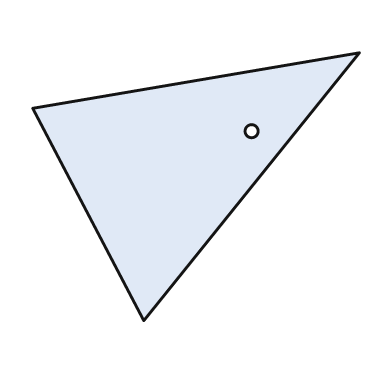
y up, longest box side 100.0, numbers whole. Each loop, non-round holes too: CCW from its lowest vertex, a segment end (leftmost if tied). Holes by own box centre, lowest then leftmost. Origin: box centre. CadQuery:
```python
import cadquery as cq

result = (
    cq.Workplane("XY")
    .moveTo(-16.0, -41.0)
    .lineTo(50.0, 41.0)
    .lineTo(-50.0, 24.0)
    .close()
    .moveTo(17.0, 17.0)
    .circle(2.0)
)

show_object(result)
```